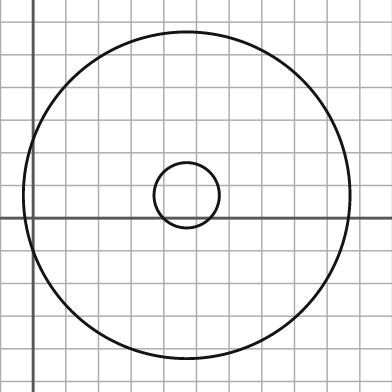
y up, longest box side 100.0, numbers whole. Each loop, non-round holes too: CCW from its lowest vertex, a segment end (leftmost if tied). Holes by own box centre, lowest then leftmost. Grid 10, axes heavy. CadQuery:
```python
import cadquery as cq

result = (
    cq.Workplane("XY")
    .moveTo(47.0, 7.0)
    .circle(50.0)
    .moveTo(47.0, 7.0)
    .circle(10.0)
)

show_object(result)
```